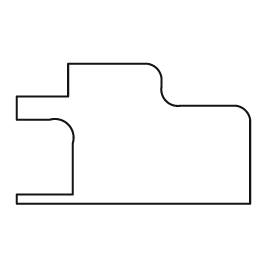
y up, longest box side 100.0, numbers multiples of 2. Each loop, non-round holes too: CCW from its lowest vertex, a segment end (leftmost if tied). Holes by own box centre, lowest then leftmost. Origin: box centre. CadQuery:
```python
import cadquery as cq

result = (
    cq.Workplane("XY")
    .moveTo(-50.0, -30.0)
    .lineTo(50.0, -30.0)
    .lineTo(50.0, 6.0)
    .threePointArc((48.0, 10.0), (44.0, 12.0))
    .lineTo(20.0, 12.0)
    .threePointArc((14.0, 14.0), (12.0, 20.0))
    .lineTo(12.0, 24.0)
    .threePointArc((10.0, 28.0), (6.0, 30.0))
    .lineTo(-28.0, 30.0)
    .lineTo(-28.0, 16.0)
    .lineTo(-50.0, 16.0)
    .lineTo(-50.0, 6.0)
    .lineTo(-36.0, 6.0)
    .threePointArc((-28.0, 4.0), (-26.0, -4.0))
    .lineTo(-26.0, -26.0)
    .lineTo(-50.0, -26.0)
    .close()
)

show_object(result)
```